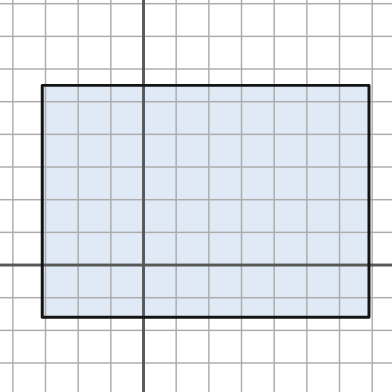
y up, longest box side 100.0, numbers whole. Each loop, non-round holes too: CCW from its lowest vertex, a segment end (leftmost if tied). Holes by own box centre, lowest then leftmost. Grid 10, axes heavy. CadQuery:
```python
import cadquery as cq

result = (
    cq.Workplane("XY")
    .moveTo(-31.0, -16.0)
    .lineTo(69.0, -16.0)
    .lineTo(69.0, 55.0)
    .lineTo(-31.0, 55.0)
    .close()
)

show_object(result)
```